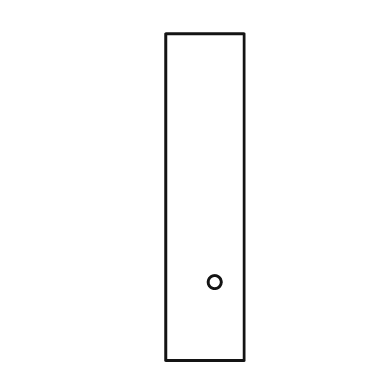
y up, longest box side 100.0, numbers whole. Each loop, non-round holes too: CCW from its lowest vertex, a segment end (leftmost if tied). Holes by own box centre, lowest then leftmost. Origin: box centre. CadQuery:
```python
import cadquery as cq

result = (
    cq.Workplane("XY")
    .moveTo(-12.0, -50.0)
    .lineTo(12.0, -50.0)
    .lineTo(12.0, 50.0)
    .lineTo(-12.0, 50.0)
    .close()
    .moveTo(3.0, -26.0)
    .circle(2.0)
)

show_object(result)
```